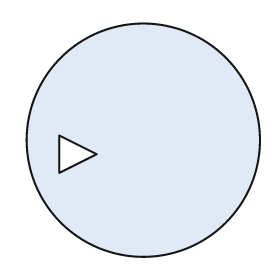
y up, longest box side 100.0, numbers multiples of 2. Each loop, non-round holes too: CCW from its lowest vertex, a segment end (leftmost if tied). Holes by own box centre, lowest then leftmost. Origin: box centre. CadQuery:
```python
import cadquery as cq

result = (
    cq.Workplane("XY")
    .moveTo(0.0, 0.0)
    .circle(50.0)
    .moveTo(-36.0, -14.0)
    .lineTo(-20.0, -6.0)
    .lineTo(-36.0, 2.0)
    .close()
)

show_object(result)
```